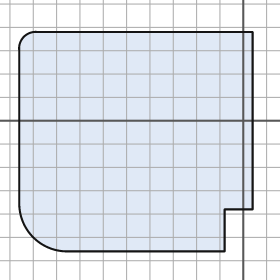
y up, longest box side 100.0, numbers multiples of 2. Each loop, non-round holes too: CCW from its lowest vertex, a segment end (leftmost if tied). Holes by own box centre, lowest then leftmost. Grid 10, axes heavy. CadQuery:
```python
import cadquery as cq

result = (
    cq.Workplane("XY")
    .moveTo(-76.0, -56.0)
    .lineTo(-8.0, -56.0)
    .lineTo(-8.0, -38.0)
    .lineTo(4.0, -38.0)
    .lineTo(4.0, 38.0)
    .lineTo(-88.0, 38.0)
    .threePointArc((-94.0, 36.0), (-96.0, 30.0))
    .lineTo(-96.0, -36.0)
    .threePointArc((-90.0, -50.0), (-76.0, -56.0))
    .close()
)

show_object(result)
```